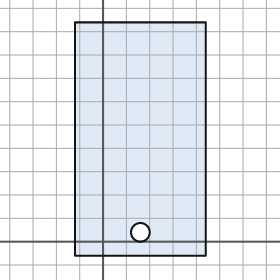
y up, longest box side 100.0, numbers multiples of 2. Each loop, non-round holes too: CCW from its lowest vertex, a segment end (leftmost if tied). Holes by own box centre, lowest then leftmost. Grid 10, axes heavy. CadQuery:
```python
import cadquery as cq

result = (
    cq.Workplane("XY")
    .moveTo(-12.0, -6.0)
    .lineTo(44.0, -6.0)
    .lineTo(44.0, 94.0)
    .lineTo(-12.0, 94.0)
    .close()
    .moveTo(16.0, 4.0)
    .circle(4.0)
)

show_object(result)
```